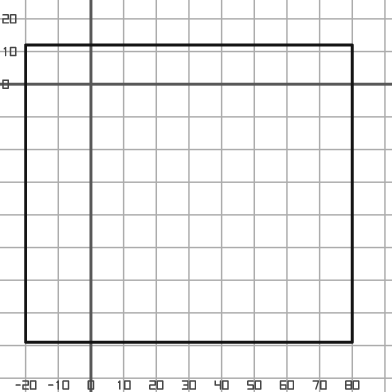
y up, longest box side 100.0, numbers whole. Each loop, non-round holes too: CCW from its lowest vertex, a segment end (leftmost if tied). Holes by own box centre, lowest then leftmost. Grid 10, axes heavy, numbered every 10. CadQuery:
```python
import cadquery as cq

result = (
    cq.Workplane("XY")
    .moveTo(-20.0, -79.0)
    .lineTo(80.0, -79.0)
    .lineTo(80.0, 12.0)
    .lineTo(-20.0, 12.0)
    .close()
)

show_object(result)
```